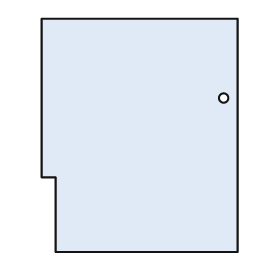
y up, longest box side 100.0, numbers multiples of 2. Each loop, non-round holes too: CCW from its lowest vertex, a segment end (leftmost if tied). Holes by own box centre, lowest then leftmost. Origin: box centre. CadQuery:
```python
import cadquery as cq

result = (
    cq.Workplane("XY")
    .moveTo(-36.0, -50.0)
    .lineTo(42.0, -50.0)
    .lineTo(42.0, 50.0)
    .lineTo(-42.0, 50.0)
    .lineTo(-42.0, -18.0)
    .lineTo(-36.0, -18.0)
    .close()
    .moveTo(36.0, 16.0)
    .circle(2.0)
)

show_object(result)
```